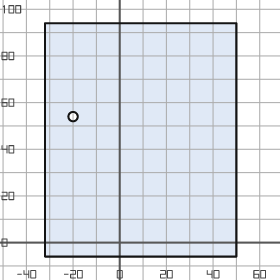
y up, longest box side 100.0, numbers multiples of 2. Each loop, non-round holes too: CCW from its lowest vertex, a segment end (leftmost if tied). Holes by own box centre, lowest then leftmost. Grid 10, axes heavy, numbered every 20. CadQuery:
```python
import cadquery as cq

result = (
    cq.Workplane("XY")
    .moveTo(-32.0, -6.0)
    .lineTo(50.0, -6.0)
    .lineTo(50.0, 94.0)
    .lineTo(-32.0, 94.0)
    .close()
    .moveTo(-20.0, 54.0)
    .circle(2.0)
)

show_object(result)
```